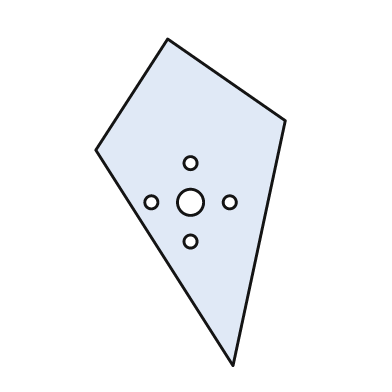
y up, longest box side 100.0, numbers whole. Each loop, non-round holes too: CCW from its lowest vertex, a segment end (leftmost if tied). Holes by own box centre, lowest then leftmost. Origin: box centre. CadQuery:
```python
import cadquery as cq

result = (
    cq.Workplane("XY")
    .moveTo(13.0, -50.0)
    .lineTo(29.0, 25.0)
    .lineTo(-7.0, 50.0)
    .lineTo(-29.0, 16.0)
    .close()
    .moveTo(0.0, -12.0)
    .circle(2.0)
    .moveTo(-12.0, 0.0)
    .circle(2.0)
    .moveTo(0.0, 0.0)
    .circle(4.0)
    .moveTo(12.0, 0.0)
    .circle(2.0)
    .moveTo(0.0, 12.0)
    .circle(2.0)
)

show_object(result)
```